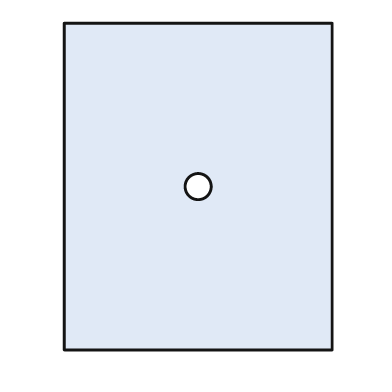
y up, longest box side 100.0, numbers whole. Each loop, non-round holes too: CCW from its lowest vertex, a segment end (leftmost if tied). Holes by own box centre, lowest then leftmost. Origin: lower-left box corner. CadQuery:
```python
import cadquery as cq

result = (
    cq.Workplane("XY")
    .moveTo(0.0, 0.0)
    .lineTo(82.0, 0.0)
    .lineTo(82.0, 100.0)
    .lineTo(0.0, 100.0)
    .close()
    .moveTo(41.0, 50.0)
    .circle(4.0)
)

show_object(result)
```